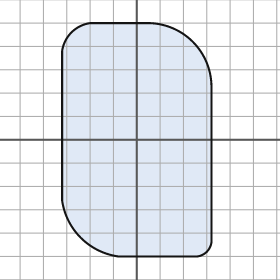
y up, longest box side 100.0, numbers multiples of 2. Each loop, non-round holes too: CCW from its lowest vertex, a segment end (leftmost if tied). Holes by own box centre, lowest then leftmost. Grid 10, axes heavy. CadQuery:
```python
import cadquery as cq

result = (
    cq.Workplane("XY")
    .moveTo(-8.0, -50.0)
    .lineTo(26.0, -50.0)
    .threePointArc((30.0, -48.0), (32.0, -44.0))
    .lineTo(32.0, 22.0)
    .threePointArc((24.0, 42.0), (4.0, 50.0))
    .lineTo(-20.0, 50.0)
    .threePointArc((-28.0, 46.0), (-32.0, 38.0))
    .lineTo(-32.0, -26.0)
    .threePointArc((-24.0, -42.0), (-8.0, -50.0))
    .close()
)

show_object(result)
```